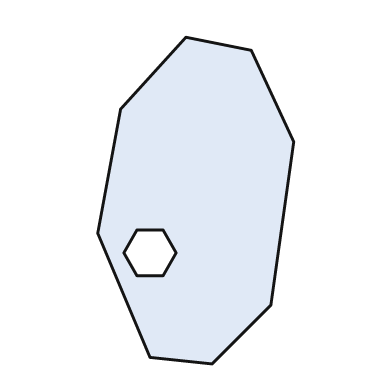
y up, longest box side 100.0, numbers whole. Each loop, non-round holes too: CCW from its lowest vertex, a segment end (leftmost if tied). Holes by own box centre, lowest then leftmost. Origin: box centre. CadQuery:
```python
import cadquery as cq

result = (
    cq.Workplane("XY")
    .moveTo(5.0, -50.0)
    .lineTo(23.0, -32.0)
    .lineTo(30.0, 18.0)
    .lineTo(17.0, 46.0)
    .lineTo(-3.0, 50.0)
    .lineTo(-23.0, 28.0)
    .lineTo(-30.0, -10.0)
    .lineTo(-14.0, -48.0)
    .close()
    .moveTo(-18.0, -23.0)
    .lineTo(-10.0, -23.0)
    .lineTo(-6.0, -16.0)
    .lineTo(-10.0, -9.0)
    .lineTo(-18.0, -9.0)
    .lineTo(-22.0, -16.0)
    .close()
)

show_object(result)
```